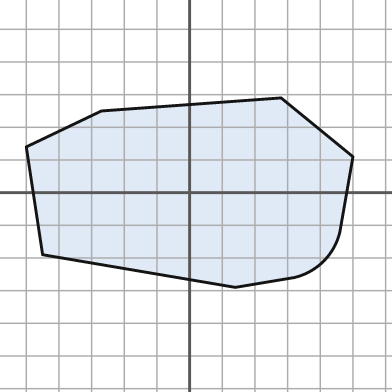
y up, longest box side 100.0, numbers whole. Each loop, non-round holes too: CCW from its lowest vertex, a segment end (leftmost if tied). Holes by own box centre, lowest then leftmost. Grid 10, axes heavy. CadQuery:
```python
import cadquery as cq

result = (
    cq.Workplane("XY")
    .moveTo(14.0, -29.0)
    .lineTo(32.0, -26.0)
    .threePointArc((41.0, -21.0), (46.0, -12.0))
    .lineTo(50.0, 11.0)
    .lineTo(28.0, 29.0)
    .lineTo(-27.0, 25.0)
    .lineTo(-50.0, 14.0)
    .lineTo(-45.0, -19.0)
    .close()
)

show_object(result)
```